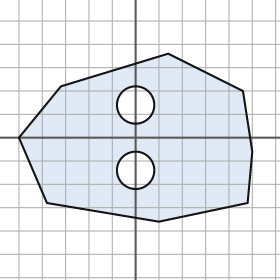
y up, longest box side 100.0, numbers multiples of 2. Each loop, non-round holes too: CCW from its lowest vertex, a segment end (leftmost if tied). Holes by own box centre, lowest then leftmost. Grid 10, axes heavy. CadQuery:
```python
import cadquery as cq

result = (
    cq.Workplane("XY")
    .moveTo(10.0, -36.0)
    .lineTo(48.0, -28.0)
    .lineTo(50.0, -6.0)
    .lineTo(46.0, 20.0)
    .lineTo(14.0, 36.0)
    .lineTo(-32.0, 22.0)
    .lineTo(-50.0, 0.0)
    .lineTo(-38.0, -28.0)
    .close()
    .moveTo(0.0, -14.0)
    .circle(8.0)
    .moveTo(0.0, 14.0)
    .circle(8.0)
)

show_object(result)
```